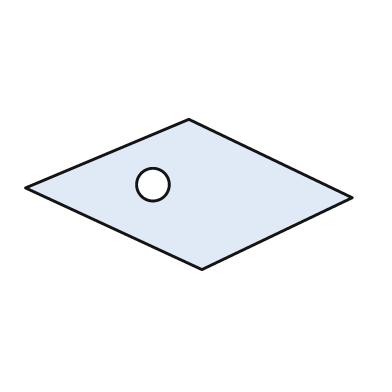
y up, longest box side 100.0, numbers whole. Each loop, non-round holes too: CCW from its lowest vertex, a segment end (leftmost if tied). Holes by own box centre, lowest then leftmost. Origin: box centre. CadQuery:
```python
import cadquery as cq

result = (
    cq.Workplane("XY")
    .moveTo(4.0, -23.0)
    .lineTo(50.0, -1.0)
    .lineTo(0.0, 23.0)
    .lineTo(-50.0, 2.0)
    .close()
    .moveTo(-11.0, 3.0)
    .circle(5.0)
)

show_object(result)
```